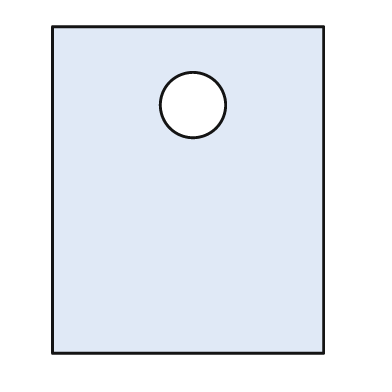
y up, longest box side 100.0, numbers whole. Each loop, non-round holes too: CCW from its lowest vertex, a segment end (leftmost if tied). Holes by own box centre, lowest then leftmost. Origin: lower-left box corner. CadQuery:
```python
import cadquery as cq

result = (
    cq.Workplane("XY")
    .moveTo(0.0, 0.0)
    .lineTo(83.0, 0.0)
    .lineTo(83.0, 100.0)
    .lineTo(0.0, 100.0)
    .close()
    .moveTo(43.0, 76.0)
    .circle(10.0)
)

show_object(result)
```